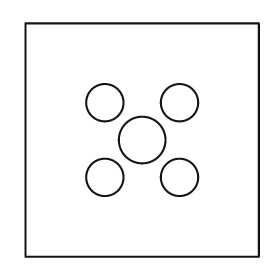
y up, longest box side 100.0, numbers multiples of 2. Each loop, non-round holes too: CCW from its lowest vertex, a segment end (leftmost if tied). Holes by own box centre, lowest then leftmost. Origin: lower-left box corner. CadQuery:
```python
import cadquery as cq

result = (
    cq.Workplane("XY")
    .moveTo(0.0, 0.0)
    .lineTo(100.0, 0.0)
    .lineTo(100.0, 100.0)
    .lineTo(0.0, 100.0)
    .close()
    .moveTo(34.0, 34.0)
    .circle(8.0)
    .moveTo(66.0, 34.0)
    .circle(8.0)
    .moveTo(50.0, 50.0)
    .circle(10.0)
    .moveTo(34.0, 66.0)
    .circle(8.0)
    .moveTo(66.0, 66.0)
    .circle(8.0)
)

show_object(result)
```